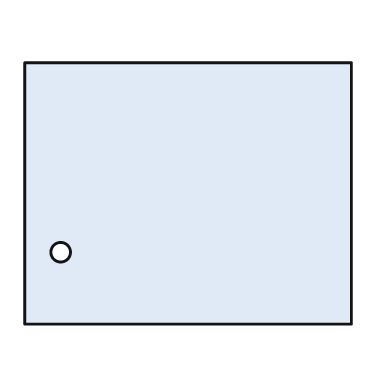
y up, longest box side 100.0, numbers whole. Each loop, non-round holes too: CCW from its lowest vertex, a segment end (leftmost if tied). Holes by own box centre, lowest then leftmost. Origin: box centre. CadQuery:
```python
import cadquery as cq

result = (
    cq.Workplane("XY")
    .moveTo(-50.0, -40.0)
    .lineTo(50.0, -40.0)
    .lineTo(50.0, 40.0)
    .lineTo(-50.0, 40.0)
    .close()
    .moveTo(-39.0, -18.0)
    .circle(3.0)
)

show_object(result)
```